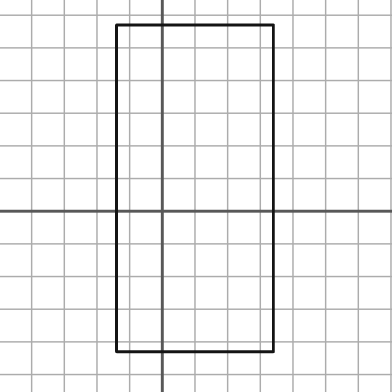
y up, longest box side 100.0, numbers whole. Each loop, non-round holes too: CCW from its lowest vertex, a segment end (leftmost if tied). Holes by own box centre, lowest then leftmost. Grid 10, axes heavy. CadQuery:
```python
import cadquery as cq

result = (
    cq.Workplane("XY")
    .moveTo(-14.0, -43.0)
    .lineTo(34.0, -43.0)
    .lineTo(34.0, 57.0)
    .lineTo(-14.0, 57.0)
    .close()
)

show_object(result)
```